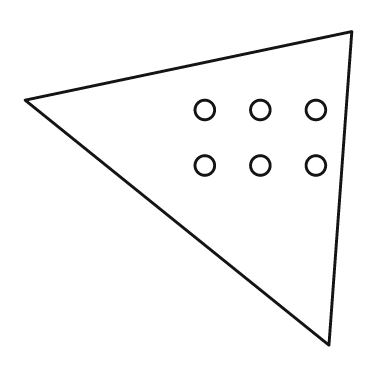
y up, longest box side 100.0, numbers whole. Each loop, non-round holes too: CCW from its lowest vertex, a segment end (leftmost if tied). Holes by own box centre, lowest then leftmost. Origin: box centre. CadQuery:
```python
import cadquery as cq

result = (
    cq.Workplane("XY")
    .moveTo(43.0, -48.0)
    .lineTo(50.0, 48.0)
    .lineTo(-50.0, 27.0)
    .close()
    .moveTo(5.0, 7.0)
    .circle(3.0)
    .moveTo(22.0, 7.0)
    .circle(3.0)
    .moveTo(39.0, 7.0)
    .circle(3.0)
    .moveTo(5.0, 24.0)
    .circle(3.0)
    .moveTo(22.0, 24.0)
    .circle(3.0)
    .moveTo(39.0, 24.0)
    .circle(3.0)
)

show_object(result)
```